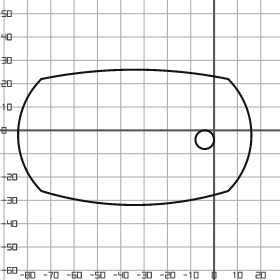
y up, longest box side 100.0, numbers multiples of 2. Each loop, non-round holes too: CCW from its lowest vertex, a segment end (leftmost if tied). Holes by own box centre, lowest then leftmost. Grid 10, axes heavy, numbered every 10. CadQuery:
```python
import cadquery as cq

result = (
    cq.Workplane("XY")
    .moveTo(-74.0, -26.0)
    .threePointArc((-34.0, -32.0), (6.0, -26.0))
    .threePointArc((16.0, -2.0), (6.0, 22.0))
    .threePointArc((-34.0, 26.0), (-74.0, 22.0))
    .threePointArc((-84.0, -2.0), (-74.0, -26.0))
    .close()
    .moveTo(-4.0, -4.0)
    .circle(4.0)
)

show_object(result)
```